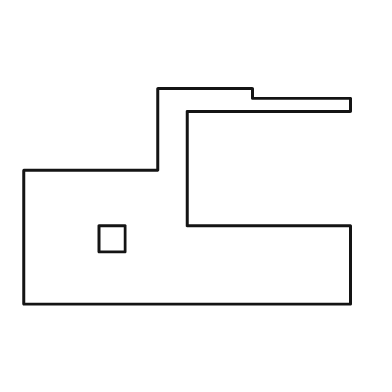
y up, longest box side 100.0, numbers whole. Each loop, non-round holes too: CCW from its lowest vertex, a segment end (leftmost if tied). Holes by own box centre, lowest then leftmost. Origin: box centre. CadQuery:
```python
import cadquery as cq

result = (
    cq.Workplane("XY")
    .moveTo(-50.0, -33.0)
    .lineTo(50.0, -33.0)
    .lineTo(50.0, -9.0)
    .lineTo(0.0, -9.0)
    .lineTo(0.0, 26.0)
    .lineTo(50.0, 26.0)
    .lineTo(50.0, 30.0)
    .lineTo(20.0, 30.0)
    .lineTo(20.0, 33.0)
    .lineTo(-9.0, 33.0)
    .lineTo(-9.0, 8.0)
    .lineTo(-50.0, 8.0)
    .close()
    .moveTo(-27.0, -17.0)
    .lineTo(-19.0, -17.0)
    .lineTo(-19.0, -9.0)
    .lineTo(-27.0, -9.0)
    .close()
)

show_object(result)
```